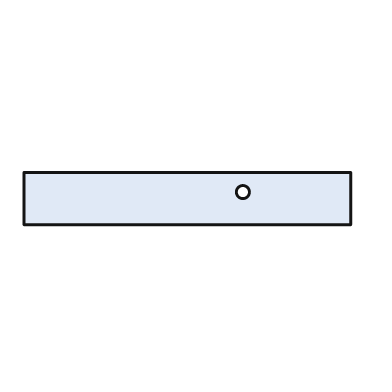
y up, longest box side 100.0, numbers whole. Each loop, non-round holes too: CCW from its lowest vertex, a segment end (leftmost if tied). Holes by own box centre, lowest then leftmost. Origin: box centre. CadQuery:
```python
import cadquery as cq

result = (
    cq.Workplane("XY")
    .moveTo(-50.0, -8.0)
    .lineTo(50.0, -8.0)
    .lineTo(50.0, 8.0)
    .lineTo(-50.0, 8.0)
    .close()
    .moveTo(17.0, 2.0)
    .circle(2.0)
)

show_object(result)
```